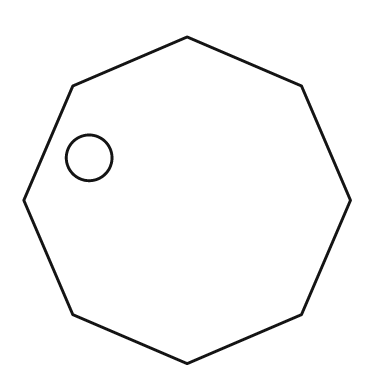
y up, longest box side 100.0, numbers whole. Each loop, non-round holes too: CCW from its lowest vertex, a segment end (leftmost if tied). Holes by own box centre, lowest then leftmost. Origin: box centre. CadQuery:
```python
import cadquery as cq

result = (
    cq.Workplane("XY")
    .moveTo(0.0, -50.0)
    .lineTo(35.0, -35.0)
    .lineTo(50.0, 0.0)
    .lineTo(35.0, 35.0)
    .lineTo(0.0, 50.0)
    .lineTo(-35.0, 35.0)
    .lineTo(-50.0, 0.0)
    .lineTo(-35.0, -35.0)
    .close()
    .moveTo(-30.0, 13.0)
    .circle(7.0)
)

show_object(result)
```